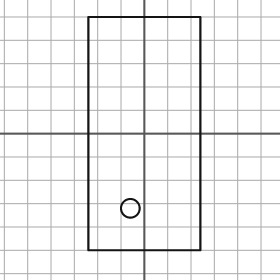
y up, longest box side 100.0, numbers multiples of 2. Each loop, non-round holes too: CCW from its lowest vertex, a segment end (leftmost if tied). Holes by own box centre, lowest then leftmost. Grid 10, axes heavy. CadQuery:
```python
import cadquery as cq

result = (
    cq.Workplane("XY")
    .moveTo(-24.0, -50.0)
    .lineTo(24.0, -50.0)
    .lineTo(24.0, 50.0)
    .lineTo(-24.0, 50.0)
    .close()
    .moveTo(-6.0, -32.0)
    .circle(4.0)
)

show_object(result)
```